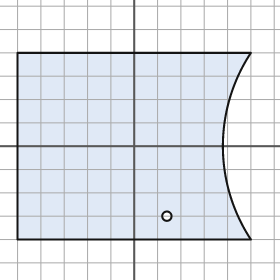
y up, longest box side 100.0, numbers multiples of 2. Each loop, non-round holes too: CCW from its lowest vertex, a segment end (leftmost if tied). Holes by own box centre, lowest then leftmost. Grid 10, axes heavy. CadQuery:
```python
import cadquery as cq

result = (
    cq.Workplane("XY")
    .moveTo(-50.0, -40.0)
    .lineTo(50.0, -40.0)
    .threePointArc((38.0, 0.0), (50.0, 40.0))
    .lineTo(-50.0, 40.0)
    .close()
    .moveTo(14.0, -30.0)
    .circle(2.0)
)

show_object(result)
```